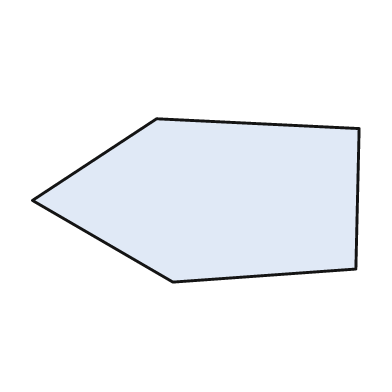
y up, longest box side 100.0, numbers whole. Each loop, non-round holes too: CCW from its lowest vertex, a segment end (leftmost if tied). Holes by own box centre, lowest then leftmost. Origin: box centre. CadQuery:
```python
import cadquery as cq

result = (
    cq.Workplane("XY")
    .moveTo(-7.0, -25.0)
    .lineTo(49.0, -21.0)
    .lineTo(50.0, 22.0)
    .lineTo(-12.0, 25.0)
    .lineTo(-50.0, 0.0)
    .close()
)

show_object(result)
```